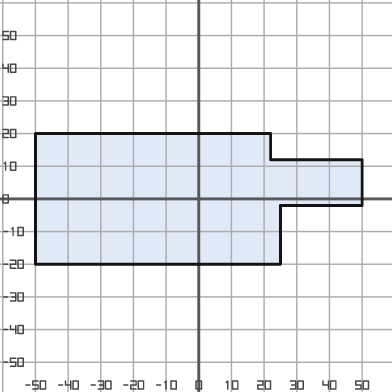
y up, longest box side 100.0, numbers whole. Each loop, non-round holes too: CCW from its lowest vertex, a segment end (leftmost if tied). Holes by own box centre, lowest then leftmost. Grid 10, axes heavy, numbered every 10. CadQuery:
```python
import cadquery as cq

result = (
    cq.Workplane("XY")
    .moveTo(-50.0, -20.0)
    .lineTo(25.0, -20.0)
    .lineTo(25.0, -2.0)
    .lineTo(50.0, -2.0)
    .lineTo(50.0, 12.0)
    .lineTo(22.0, 12.0)
    .lineTo(22.0, 20.0)
    .lineTo(-50.0, 20.0)
    .close()
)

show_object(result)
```